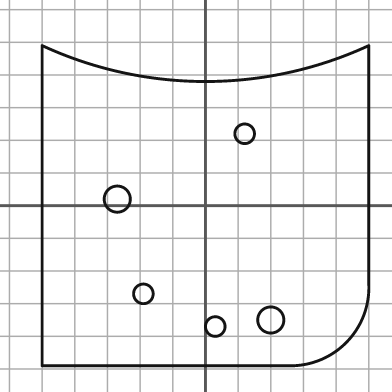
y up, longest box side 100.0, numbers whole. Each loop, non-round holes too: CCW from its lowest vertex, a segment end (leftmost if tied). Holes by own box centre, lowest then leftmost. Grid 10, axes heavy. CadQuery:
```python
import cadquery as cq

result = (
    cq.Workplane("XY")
    .moveTo(-50.0, -49.0)
    .lineTo(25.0, -49.0)
    .threePointArc((43.0, -42.0), (50.0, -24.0))
    .lineTo(50.0, 49.0)
    .threePointArc((0.0, 38.0), (-50.0, 49.0))
    .close()
    .moveTo(3.0, -37.0)
    .circle(3.0)
    .moveTo(20.0, -35.0)
    .circle(4.0)
    .moveTo(-19.0, -27.0)
    .circle(3.0)
    .moveTo(-27.0, 2.0)
    .circle(4.0)
    .moveTo(12.0, 22.0)
    .circle(3.0)
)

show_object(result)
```